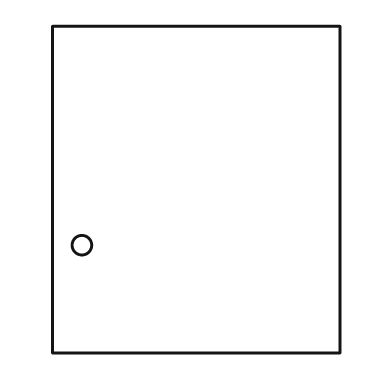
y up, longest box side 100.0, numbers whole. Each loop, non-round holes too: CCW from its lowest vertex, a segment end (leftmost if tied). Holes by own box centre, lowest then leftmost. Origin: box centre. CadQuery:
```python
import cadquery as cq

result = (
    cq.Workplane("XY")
    .moveTo(-44.0, -50.0)
    .lineTo(44.0, -50.0)
    .lineTo(44.0, 50.0)
    .lineTo(-44.0, 50.0)
    .close()
    .moveTo(-35.0, -17.0)
    .circle(3.0)
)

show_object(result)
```